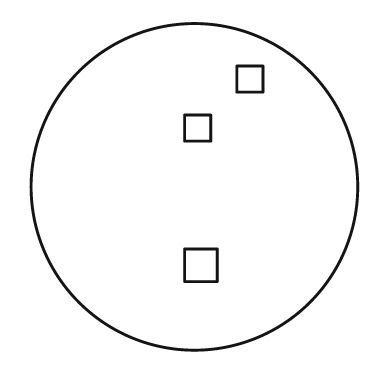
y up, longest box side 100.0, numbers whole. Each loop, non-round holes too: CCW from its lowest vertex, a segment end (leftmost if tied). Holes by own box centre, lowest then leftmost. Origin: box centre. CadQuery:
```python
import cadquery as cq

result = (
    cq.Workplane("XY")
    .moveTo(0.0, 0.0)
    .circle(50.0)
    .moveTo(-3.0, -29.0)
    .lineTo(7.0, -29.0)
    .lineTo(7.0, -19.0)
    .lineTo(-3.0, -19.0)
    .close()
    .moveTo(-3.0, 14.0)
    .lineTo(5.0, 14.0)
    .lineTo(5.0, 22.0)
    .lineTo(-3.0, 22.0)
    .close()
    .moveTo(13.0, 29.0)
    .lineTo(21.0, 29.0)
    .lineTo(21.0, 37.0)
    .lineTo(13.0, 37.0)
    .close()
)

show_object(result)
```